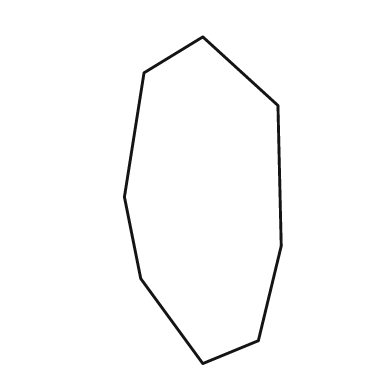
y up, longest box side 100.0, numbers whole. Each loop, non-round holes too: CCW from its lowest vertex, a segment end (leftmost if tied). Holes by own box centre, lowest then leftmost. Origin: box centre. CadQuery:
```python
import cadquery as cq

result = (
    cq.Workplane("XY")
    .moveTo(0.0, -50.0)
    .lineTo(17.0, -43.0)
    .lineTo(24.0, -14.0)
    .lineTo(23.0, 29.0)
    .lineTo(0.0, 50.0)
    .lineTo(-18.0, 39.0)
    .lineTo(-24.0, 1.0)
    .lineTo(-19.0, -24.0)
    .close()
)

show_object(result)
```